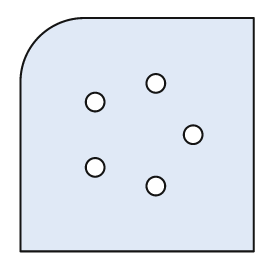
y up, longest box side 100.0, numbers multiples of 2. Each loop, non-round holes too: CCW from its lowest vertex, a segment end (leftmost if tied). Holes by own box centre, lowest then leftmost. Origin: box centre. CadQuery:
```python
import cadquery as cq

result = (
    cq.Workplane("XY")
    .moveTo(-50.0, -50.0)
    .lineTo(50.0, -50.0)
    .lineTo(50.0, 50.0)
    .lineTo(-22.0, 50.0)
    .threePointArc((-42.0, 42.0), (-50.0, 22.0))
    .close()
    .moveTo(8.0, -22.0)
    .circle(4.0)
    .moveTo(-18.0, -14.0)
    .circle(4.0)
    .moveTo(24.0, 0.0)
    .circle(4.0)
    .moveTo(-18.0, 14.0)
    .circle(4.0)
    .moveTo(8.0, 22.0)
    .circle(4.0)
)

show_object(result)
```